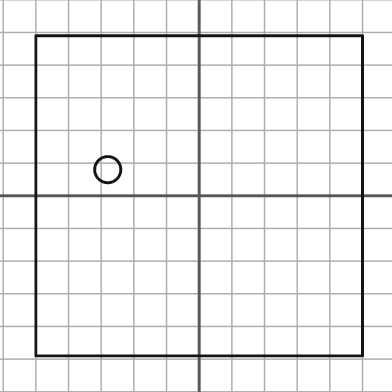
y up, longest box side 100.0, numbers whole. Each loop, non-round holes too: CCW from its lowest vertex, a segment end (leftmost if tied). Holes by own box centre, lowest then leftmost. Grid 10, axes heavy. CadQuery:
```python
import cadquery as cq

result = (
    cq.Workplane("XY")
    .moveTo(-50.0, -49.0)
    .lineTo(50.0, -49.0)
    .lineTo(50.0, 49.0)
    .lineTo(-50.0, 49.0)
    .close()
    .moveTo(-28.0, 8.0)
    .circle(4.0)
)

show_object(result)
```